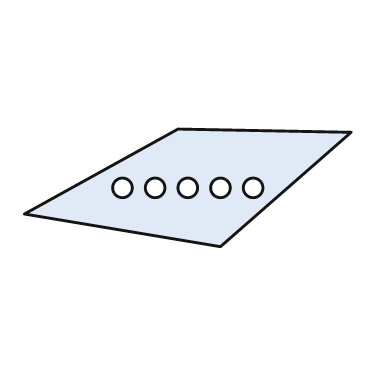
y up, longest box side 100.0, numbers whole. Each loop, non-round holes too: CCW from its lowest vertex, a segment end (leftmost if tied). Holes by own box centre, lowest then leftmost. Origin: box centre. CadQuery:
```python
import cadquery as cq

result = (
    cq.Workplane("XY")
    .moveTo(10.0, -18.0)
    .lineTo(50.0, 17.0)
    .lineTo(-3.0, 18.0)
    .lineTo(-50.0, -8.0)
    .close()
    .moveTo(-20.0, 0.0)
    .circle(3.0)
    .moveTo(-10.0, 0.0)
    .circle(3.0)
    .moveTo(0.0, 0.0)
    .circle(3.0)
    .moveTo(10.0, 0.0)
    .circle(3.0)
    .moveTo(20.0, 0.0)
    .circle(3.0)
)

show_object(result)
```